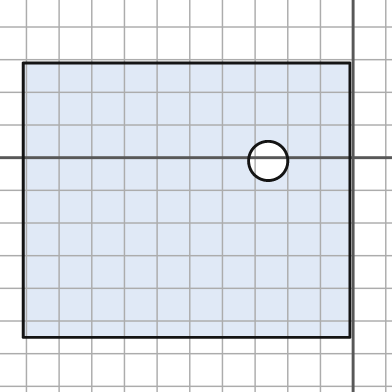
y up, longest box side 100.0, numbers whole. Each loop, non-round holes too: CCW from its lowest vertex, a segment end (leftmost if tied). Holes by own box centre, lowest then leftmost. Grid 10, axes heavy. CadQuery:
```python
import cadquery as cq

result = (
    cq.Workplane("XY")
    .moveTo(-101.0, -55.0)
    .lineTo(-1.0, -55.0)
    .lineTo(-1.0, 29.0)
    .lineTo(-101.0, 29.0)
    .close()
    .moveTo(-26.0, -1.0)
    .circle(6.0)
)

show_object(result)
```